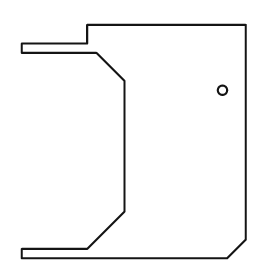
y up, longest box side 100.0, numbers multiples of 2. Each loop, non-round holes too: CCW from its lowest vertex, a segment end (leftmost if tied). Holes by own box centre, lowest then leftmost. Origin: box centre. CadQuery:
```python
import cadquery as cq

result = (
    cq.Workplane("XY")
    .moveTo(-48.0, -50.0)
    .lineTo(40.0, -50.0)
    .lineTo(48.0, -42.0)
    .lineTo(48.0, 50.0)
    .lineTo(-20.0, 50.0)
    .lineTo(-20.0, 42.0)
    .lineTo(-48.0, 42.0)
    .lineTo(-48.0, 38.0)
    .lineTo(-16.0, 38.0)
    .lineTo(-4.0, 26.0)
    .lineTo(-4.0, -30.0)
    .lineTo(-20.0, -46.0)
    .lineTo(-48.0, -46.0)
    .close()
    .moveTo(38.0, 22.0)
    .circle(2.0)
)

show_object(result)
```